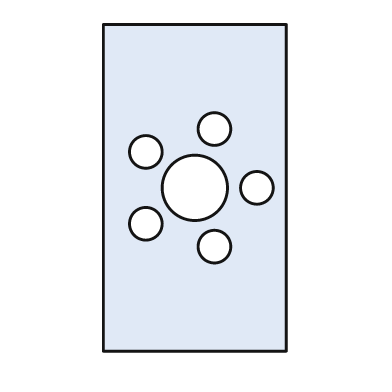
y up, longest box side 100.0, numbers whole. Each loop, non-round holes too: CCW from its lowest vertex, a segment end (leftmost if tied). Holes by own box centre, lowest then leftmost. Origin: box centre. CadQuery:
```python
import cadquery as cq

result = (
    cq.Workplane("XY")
    .moveTo(-28.0, -50.0)
    .lineTo(28.0, -50.0)
    .lineTo(28.0, 50.0)
    .lineTo(-28.0, 50.0)
    .close()
    .moveTo(6.0, -18.0)
    .circle(5.0)
    .moveTo(-15.0, -11.0)
    .circle(5.0)
    .moveTo(0.0, 0.0)
    .circle(10.0)
    .moveTo(19.0, 0.0)
    .circle(5.0)
    .moveTo(-15.0, 11.0)
    .circle(5.0)
    .moveTo(6.0, 18.0)
    .circle(5.0)
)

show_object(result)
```